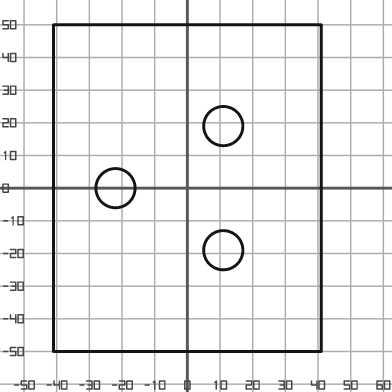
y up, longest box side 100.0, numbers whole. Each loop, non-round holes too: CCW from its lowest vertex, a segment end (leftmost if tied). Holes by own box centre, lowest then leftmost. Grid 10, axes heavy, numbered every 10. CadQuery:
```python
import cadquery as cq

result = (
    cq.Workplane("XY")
    .moveTo(-41.0, -50.0)
    .lineTo(41.0, -50.0)
    .lineTo(41.0, 50.0)
    .lineTo(-41.0, 50.0)
    .close()
    .moveTo(11.0, -19.0)
    .circle(6.0)
    .moveTo(-22.0, 0.0)
    .circle(6.0)
    .moveTo(11.0, 19.0)
    .circle(6.0)
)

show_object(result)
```